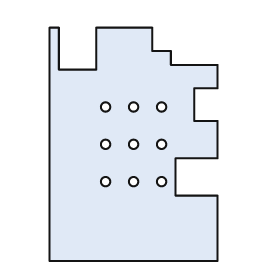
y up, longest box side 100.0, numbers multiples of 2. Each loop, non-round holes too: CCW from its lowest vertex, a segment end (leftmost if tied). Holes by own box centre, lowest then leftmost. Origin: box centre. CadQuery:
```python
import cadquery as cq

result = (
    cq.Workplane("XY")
    .moveTo(-36.0, -50.0)
    .lineTo(36.0, -50.0)
    .lineTo(36.0, -22.0)
    .lineTo(18.0, -22.0)
    .lineTo(18.0, -6.0)
    .lineTo(36.0, -6.0)
    .lineTo(36.0, 10.0)
    .lineTo(26.0, 10.0)
    .lineTo(26.0, 24.0)
    .lineTo(36.0, 24.0)
    .lineTo(36.0, 34.0)
    .lineTo(16.0, 34.0)
    .lineTo(16.0, 40.0)
    .lineTo(8.0, 40.0)
    .lineTo(8.0, 50.0)
    .lineTo(-16.0, 50.0)
    .lineTo(-16.0, 32.0)
    .lineTo(-32.0, 32.0)
    .lineTo(-32.0, 50.0)
    .lineTo(-36.0, 50.0)
    .close()
    .moveTo(-12.0, -16.0)
    .circle(2.0)
    .moveTo(0.0, -16.0)
    .circle(2.0)
    .moveTo(12.0, -16.0)
    .circle(2.0)
    .moveTo(-12.0, 0.0)
    .circle(2.0)
    .moveTo(0.0, 0.0)
    .circle(2.0)
    .moveTo(12.0, 0.0)
    .circle(2.0)
    .moveTo(-12.0, 16.0)
    .circle(2.0)
    .moveTo(0.0, 16.0)
    .circle(2.0)
    .moveTo(12.0, 16.0)
    .circle(2.0)
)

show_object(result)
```